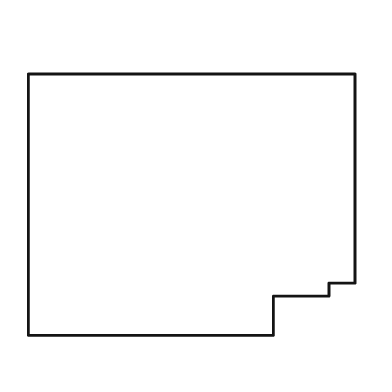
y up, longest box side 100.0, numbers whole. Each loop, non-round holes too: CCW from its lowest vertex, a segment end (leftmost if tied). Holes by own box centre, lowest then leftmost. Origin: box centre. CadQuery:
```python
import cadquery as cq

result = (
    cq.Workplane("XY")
    .moveTo(-50.0, -40.0)
    .lineTo(25.0, -40.0)
    .lineTo(25.0, -28.0)
    .lineTo(42.0, -28.0)
    .lineTo(42.0, -24.0)
    .lineTo(50.0, -24.0)
    .lineTo(50.0, 40.0)
    .lineTo(-50.0, 40.0)
    .close()
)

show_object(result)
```